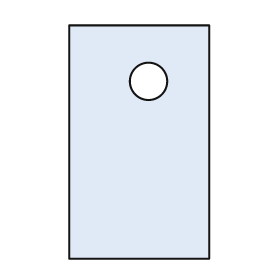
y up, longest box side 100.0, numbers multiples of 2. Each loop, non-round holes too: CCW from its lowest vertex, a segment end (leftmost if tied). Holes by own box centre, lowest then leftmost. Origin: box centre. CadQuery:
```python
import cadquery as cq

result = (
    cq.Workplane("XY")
    .moveTo(-30.0, -50.0)
    .lineTo(30.0, -50.0)
    .lineTo(30.0, 50.0)
    .lineTo(-30.0, 50.0)
    .close()
    .moveTo(4.0, 26.0)
    .circle(8.0)
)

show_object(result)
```